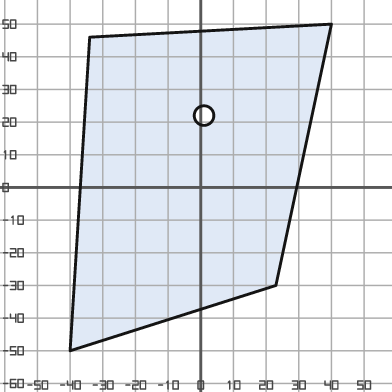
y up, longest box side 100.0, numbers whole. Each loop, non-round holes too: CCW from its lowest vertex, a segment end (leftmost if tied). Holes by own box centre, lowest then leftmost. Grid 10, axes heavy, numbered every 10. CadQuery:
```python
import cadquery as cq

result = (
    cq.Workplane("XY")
    .moveTo(-40.0, -50.0)
    .lineTo(23.0, -30.0)
    .lineTo(40.0, 50.0)
    .lineTo(-34.0, 46.0)
    .close()
    .moveTo(1.0, 22.0)
    .circle(3.0)
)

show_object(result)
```